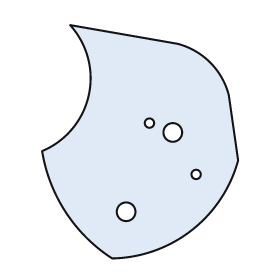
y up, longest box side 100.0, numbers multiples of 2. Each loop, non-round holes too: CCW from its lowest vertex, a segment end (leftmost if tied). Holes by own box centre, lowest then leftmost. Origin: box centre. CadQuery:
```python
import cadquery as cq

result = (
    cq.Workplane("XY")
    .moveTo(-12.0, -50.0)
    .threePointArc((22.0, -38.0), (42.0, -8.0))
    .lineTo(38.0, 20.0)
    .threePointArc((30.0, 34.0), (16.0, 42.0))
    .lineTo(-30.0, 50.0)
    .threePointArc((-22.0, 20.0), (-42.0, -4.0))
    .threePointArc((-32.0, -30.0), (-12.0, -50.0))
    .close()
    .moveTo(-6.0, -30.0)
    .circle(4.0)
    .moveTo(24.0, -14.0)
    .circle(2.0)
    .moveTo(14.0, 4.0)
    .circle(4.0)
    .moveTo(4.0, 8.0)
    .circle(2.0)
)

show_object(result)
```